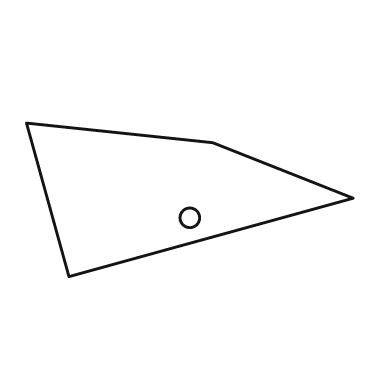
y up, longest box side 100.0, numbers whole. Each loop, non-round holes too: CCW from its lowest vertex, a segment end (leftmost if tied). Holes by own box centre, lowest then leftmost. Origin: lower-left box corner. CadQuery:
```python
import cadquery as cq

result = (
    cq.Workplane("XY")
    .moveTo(13.0, 0.0)
    .lineTo(100.0, 24.0)
    .lineTo(57.0, 41.0)
    .lineTo(0.0, 47.0)
    .close()
    .moveTo(50.0, 18.0)
    .circle(3.0)
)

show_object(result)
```